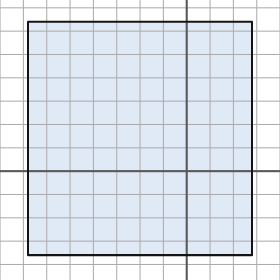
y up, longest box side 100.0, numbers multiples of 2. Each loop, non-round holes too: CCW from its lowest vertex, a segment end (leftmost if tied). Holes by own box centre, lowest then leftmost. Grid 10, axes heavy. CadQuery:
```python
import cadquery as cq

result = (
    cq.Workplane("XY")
    .moveTo(-68.0, -36.0)
    .lineTo(28.0, -36.0)
    .lineTo(28.0, 64.0)
    .lineTo(-68.0, 64.0)
    .close()
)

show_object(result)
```